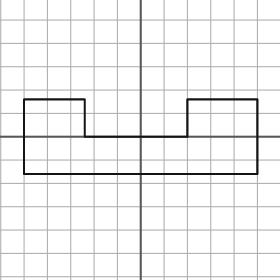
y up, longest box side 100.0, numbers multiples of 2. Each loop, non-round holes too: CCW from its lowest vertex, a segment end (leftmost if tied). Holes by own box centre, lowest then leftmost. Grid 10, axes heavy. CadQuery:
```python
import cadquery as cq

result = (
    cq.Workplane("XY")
    .moveTo(-50.0, -16.0)
    .lineTo(50.0, -16.0)
    .lineTo(50.0, 16.0)
    .lineTo(20.0, 16.0)
    .lineTo(20.0, 0.0)
    .lineTo(-24.0, 0.0)
    .lineTo(-24.0, 16.0)
    .lineTo(-50.0, 16.0)
    .close()
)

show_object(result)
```